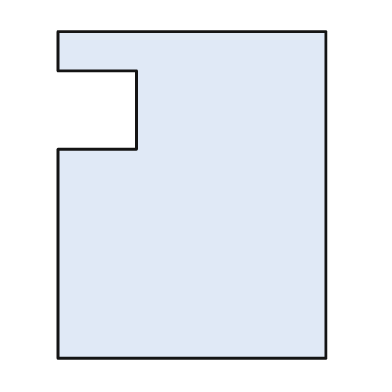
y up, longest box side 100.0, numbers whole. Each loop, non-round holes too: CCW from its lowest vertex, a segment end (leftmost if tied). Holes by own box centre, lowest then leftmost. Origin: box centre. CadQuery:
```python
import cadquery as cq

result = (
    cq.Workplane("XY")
    .moveTo(-41.0, -50.0)
    .lineTo(41.0, -50.0)
    .lineTo(41.0, 50.0)
    .lineTo(-41.0, 50.0)
    .lineTo(-41.0, 38.0)
    .lineTo(-17.0, 38.0)
    .lineTo(-17.0, 14.0)
    .lineTo(-41.0, 14.0)
    .close()
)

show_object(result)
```